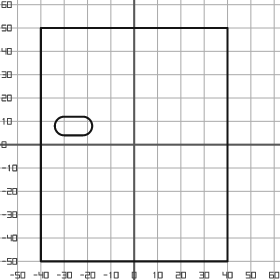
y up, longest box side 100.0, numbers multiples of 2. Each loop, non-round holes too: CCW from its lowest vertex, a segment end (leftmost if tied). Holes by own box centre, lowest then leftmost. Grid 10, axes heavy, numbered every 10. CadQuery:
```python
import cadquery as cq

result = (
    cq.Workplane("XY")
    .moveTo(-40.0, -50.0)
    .lineTo(40.0, -50.0)
    .lineTo(40.0, 50.0)
    .lineTo(-40.0, 50.0)
    .close()
    .moveTo(-30.0, 4.0)
    .lineTo(-22.0, 4.0)
    .threePointArc((-18.0, 8.0), (-22.0, 12.0))
    .lineTo(-30.0, 12.0)
    .threePointArc((-34.0, 8.0), (-30.0, 4.0))
    .close()
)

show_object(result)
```